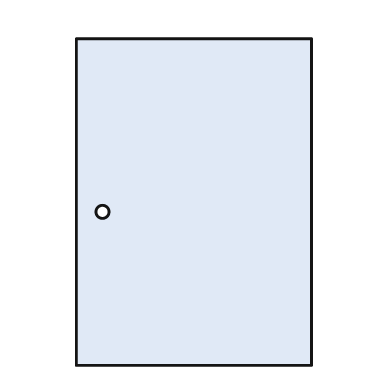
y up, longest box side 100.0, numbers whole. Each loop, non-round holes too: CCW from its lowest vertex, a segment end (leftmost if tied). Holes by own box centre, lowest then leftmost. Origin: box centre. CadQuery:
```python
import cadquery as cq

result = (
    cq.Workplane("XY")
    .moveTo(-36.0, -50.0)
    .lineTo(36.0, -50.0)
    .lineTo(36.0, 50.0)
    .lineTo(-36.0, 50.0)
    .close()
    .moveTo(-28.0, -3.0)
    .circle(2.0)
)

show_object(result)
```